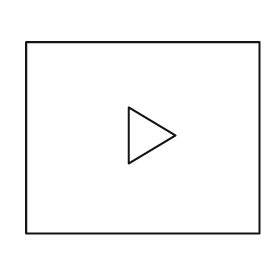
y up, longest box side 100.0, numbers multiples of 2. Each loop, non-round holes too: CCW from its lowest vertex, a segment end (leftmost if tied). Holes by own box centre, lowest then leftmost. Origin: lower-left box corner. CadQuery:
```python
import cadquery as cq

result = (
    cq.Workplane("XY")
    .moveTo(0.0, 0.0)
    .lineTo(100.0, 0.0)
    .lineTo(100.0, 82.0)
    .lineTo(0.0, 82.0)
    .close()
    .moveTo(44.0, 30.0)
    .lineTo(64.0, 42.0)
    .lineTo(44.0, 54.0)
    .close()
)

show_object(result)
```